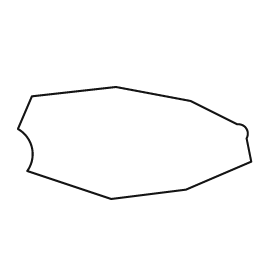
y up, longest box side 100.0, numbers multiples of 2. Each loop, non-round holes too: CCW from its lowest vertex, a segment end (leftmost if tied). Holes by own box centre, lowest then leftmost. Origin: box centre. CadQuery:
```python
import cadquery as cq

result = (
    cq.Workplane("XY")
    .moveTo(-10.0, -24.0)
    .lineTo(22.0, -20.0)
    .lineTo(50.0, -8.0)
    .lineTo(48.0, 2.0)
    .threePointArc((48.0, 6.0), (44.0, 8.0))
    .lineTo(24.0, 18.0)
    .lineTo(-8.0, 24.0)
    .lineTo(-44.0, 20.0)
    .lineTo(-50.0, 6.0)
    .threePointArc((-44.0, -2.0), (-46.0, -12.0))
    .close()
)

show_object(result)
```